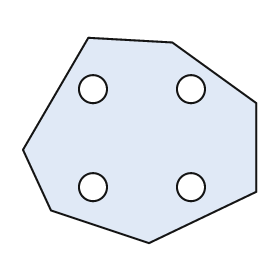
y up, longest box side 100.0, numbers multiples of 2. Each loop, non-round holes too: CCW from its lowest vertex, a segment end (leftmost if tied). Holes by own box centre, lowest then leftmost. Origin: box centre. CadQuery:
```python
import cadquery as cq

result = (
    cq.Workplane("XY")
    .moveTo(4.0, -44.0)
    .lineTo(50.0, -22.0)
    .lineTo(50.0, 16.0)
    .lineTo(14.0, 42.0)
    .lineTo(-22.0, 44.0)
    .lineTo(-50.0, -4.0)
    .lineTo(-38.0, -30.0)
    .close()
    .moveTo(-20.0, -20.0)
    .circle(6.0)
    .moveTo(22.0, -20.0)
    .circle(6.0)
    .moveTo(-20.0, 22.0)
    .circle(6.0)
    .moveTo(22.0, 22.0)
    .circle(6.0)
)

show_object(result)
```